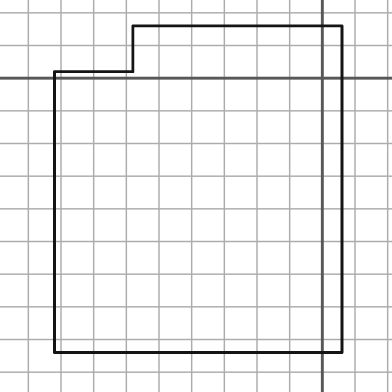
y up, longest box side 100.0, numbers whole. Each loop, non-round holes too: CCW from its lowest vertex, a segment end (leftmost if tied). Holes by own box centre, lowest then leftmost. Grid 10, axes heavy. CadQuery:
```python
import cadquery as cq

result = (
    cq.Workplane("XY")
    .moveTo(-82.0, -84.0)
    .lineTo(6.0, -84.0)
    .lineTo(6.0, 16.0)
    .lineTo(-58.0, 16.0)
    .lineTo(-58.0, 2.0)
    .lineTo(-82.0, 2.0)
    .close()
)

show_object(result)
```